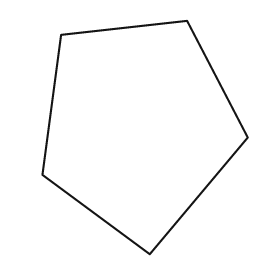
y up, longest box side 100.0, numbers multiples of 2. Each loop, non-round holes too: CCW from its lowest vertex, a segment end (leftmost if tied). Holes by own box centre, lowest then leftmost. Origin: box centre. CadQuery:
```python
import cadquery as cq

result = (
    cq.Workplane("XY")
    .moveTo(2.0, -50.0)
    .lineTo(44.0, 0.0)
    .lineTo(18.0, 50.0)
    .lineTo(-36.0, 44.0)
    .lineTo(-44.0, -16.0)
    .close()
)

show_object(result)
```